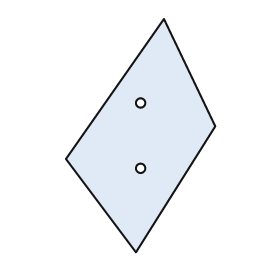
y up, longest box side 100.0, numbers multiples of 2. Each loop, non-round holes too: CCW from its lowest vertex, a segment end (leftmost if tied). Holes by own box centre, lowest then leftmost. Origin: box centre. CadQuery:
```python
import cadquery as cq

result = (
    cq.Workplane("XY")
    .moveTo(-2.0, -50.0)
    .lineTo(32.0, 4.0)
    .lineTo(10.0, 50.0)
    .lineTo(-32.0, -10.0)
    .close()
    .moveTo(0.0, -14.0)
    .circle(2.0)
    .moveTo(0.0, 14.0)
    .circle(2.0)
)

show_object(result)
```